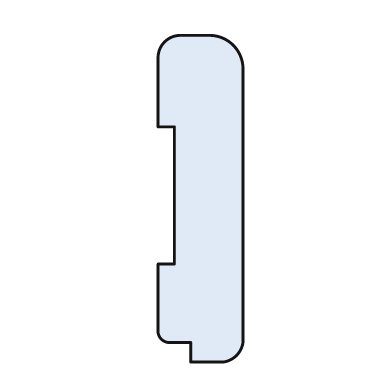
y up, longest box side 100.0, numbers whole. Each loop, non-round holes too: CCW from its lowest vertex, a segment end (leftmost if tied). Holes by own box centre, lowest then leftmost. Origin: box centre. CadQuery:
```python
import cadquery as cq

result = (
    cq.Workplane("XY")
    .moveTo(-3.0, -50.0)
    .lineTo(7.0, -50.0)
    .threePointArc((11.0, -48.0), (13.0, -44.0))
    .lineTo(13.0, 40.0)
    .threePointArc((10.0, 47.0), (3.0, 50.0))
    .lineTo(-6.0, 50.0)
    .threePointArc((-11.0, 48.0), (-13.0, 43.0))
    .lineTo(-13.0, 22.0)
    .lineTo(-8.0, 22.0)
    .lineTo(-8.0, -20.0)
    .lineTo(-13.0, -20.0)
    .lineTo(-13.0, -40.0)
    .threePointArc((-12.0, -43.0), (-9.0, -44.0))
    .lineTo(-3.0, -44.0)
    .close()
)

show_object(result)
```